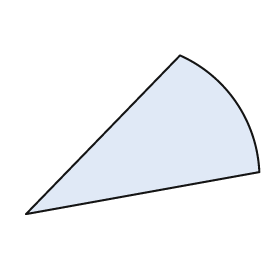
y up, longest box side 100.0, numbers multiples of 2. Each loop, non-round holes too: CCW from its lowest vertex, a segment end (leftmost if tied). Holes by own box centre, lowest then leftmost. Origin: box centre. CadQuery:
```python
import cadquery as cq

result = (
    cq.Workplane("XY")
    .moveTo(-50.0, -34.0)
    .lineTo(50.0, -16.0)
    .threePointArc((40.0, 14.0), (16.0, 34.0))
    .close()
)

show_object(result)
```